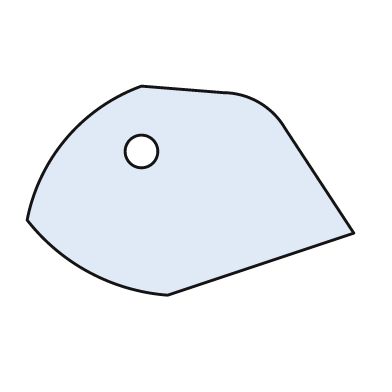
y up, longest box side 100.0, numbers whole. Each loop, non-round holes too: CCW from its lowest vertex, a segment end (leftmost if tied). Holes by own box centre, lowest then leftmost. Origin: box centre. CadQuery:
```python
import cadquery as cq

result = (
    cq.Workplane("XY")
    .moveTo(-7.0, -32.0)
    .lineTo(50.0, -13.0)
    .lineTo(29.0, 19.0)
    .threePointArc((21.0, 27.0), (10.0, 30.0))
    .lineTo(-15.0, 32.0)
    .threePointArc((-38.0, 16.0), (-50.0, -9.0))
    .threePointArc((-31.0, -25.0), (-7.0, -32.0))
    .close()
    .moveTo(-15.0, 12.0)
    .circle(5.0)
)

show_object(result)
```